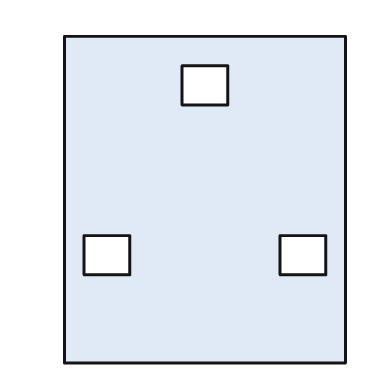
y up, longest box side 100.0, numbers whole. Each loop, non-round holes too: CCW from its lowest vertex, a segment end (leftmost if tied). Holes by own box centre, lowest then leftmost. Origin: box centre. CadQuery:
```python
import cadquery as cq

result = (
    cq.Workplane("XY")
    .moveTo(-43.0, -50.0)
    .lineTo(43.0, -50.0)
    .lineTo(43.0, 50.0)
    .lineTo(-43.0, 50.0)
    .close()
    .moveTo(-37.0, -23.0)
    .lineTo(-23.0, -23.0)
    .lineTo(-23.0, -11.0)
    .lineTo(-37.0, -11.0)
    .close()
    .moveTo(23.0, -23.0)
    .lineTo(37.0, -23.0)
    .lineTo(37.0, -11.0)
    .lineTo(23.0, -11.0)
    .close()
    .moveTo(-7.0, 29.0)
    .lineTo(7.0, 29.0)
    .lineTo(7.0, 41.0)
    .lineTo(-7.0, 41.0)
    .close()
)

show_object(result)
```